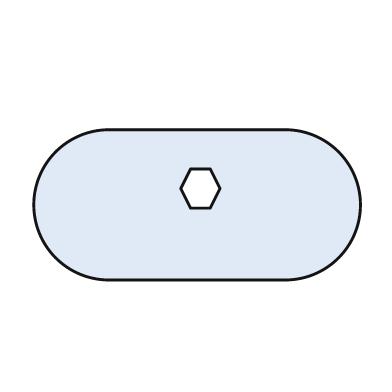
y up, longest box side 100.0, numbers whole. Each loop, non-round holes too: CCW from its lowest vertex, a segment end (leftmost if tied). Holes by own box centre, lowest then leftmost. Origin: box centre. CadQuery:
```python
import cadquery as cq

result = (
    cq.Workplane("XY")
    .moveTo(-27.0, -23.0)
    .lineTo(27.0, -23.0)
    .threePointArc((50.0, 0.0), (27.0, 23.0))
    .lineTo(-27.0, 23.0)
    .threePointArc((-50.0, 0.0), (-27.0, -23.0))
    .close()
    .moveTo(-2.0, -1.0)
    .lineTo(4.0, -1.0)
    .lineTo(7.0, 5.0)
    .lineTo(4.0, 11.0)
    .lineTo(-2.0, 11.0)
    .lineTo(-5.0, 5.0)
    .close()
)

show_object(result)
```